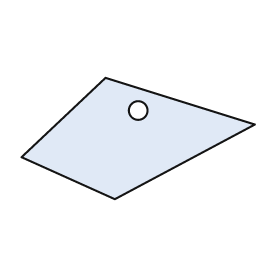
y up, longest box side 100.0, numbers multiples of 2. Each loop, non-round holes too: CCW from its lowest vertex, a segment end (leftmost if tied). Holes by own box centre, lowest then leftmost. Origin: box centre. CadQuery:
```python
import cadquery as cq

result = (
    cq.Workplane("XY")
    .moveTo(-10.0, -26.0)
    .lineTo(50.0, 6.0)
    .lineTo(-14.0, 26.0)
    .lineTo(-50.0, -8.0)
    .close()
    .moveTo(0.0, 12.0)
    .circle(4.0)
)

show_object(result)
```